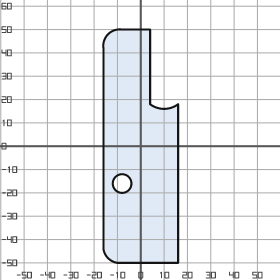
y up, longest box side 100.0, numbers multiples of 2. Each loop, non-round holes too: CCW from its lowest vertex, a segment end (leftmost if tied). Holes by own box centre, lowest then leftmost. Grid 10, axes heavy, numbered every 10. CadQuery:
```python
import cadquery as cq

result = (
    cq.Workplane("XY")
    .moveTo(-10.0, -50.0)
    .lineTo(16.0, -50.0)
    .lineTo(16.0, 18.0)
    .threePointArc((10.0, 16.0), (4.0, 18.0))
    .lineTo(4.0, 50.0)
    .lineTo(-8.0, 50.0)
    .threePointArc((-14.0, 48.0), (-16.0, 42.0))
    .lineTo(-16.0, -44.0)
    .threePointArc((-14.0, -48.0), (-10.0, -50.0))
    .close()
    .moveTo(-8.0, -16.0)
    .circle(4.0)
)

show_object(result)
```